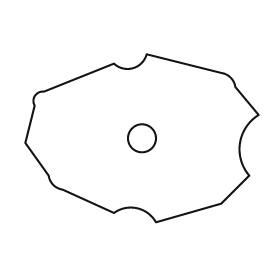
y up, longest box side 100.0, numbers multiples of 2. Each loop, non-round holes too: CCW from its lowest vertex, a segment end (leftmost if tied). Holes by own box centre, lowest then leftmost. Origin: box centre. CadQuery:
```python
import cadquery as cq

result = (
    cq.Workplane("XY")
    .moveTo(6.0, -36.0)
    .lineTo(34.0, -28.0)
    .lineTo(46.0, -16.0)
    .threePointArc((42.0, -2.0), (50.0, 10.0))
    .lineTo(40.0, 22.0)
    .threePointArc((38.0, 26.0), (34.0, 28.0))
    .lineTo(2.0, 36.0)
    .threePointArc((-4.0, 30.0), (-12.0, 32.0))
    .lineTo(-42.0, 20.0)
    .threePointArc((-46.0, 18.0), (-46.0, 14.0))
    .lineTo(-50.0, -2.0)
    .lineTo(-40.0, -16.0)
    .threePointArc((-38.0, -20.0), (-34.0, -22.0))
    .lineTo(-12.0, -32.0)
    .threePointArc((-2.0, -30.0), (6.0, -36.0))
    .close()
    .moveTo(0.0, 0.0)
    .circle(6.0)
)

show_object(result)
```